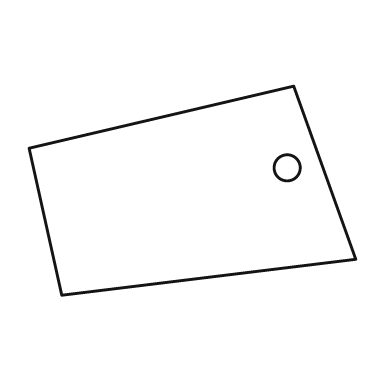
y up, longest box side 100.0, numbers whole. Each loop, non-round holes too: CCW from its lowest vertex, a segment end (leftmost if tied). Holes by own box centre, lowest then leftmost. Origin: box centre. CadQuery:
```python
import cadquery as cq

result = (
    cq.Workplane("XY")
    .moveTo(-40.0, -32.0)
    .lineTo(50.0, -21.0)
    .lineTo(31.0, 32.0)
    .lineTo(-50.0, 13.0)
    .close()
    .moveTo(29.0, 7.0)
    .circle(4.0)
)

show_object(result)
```